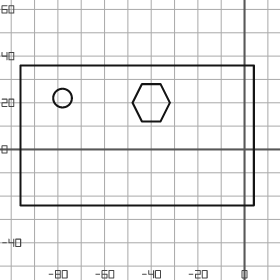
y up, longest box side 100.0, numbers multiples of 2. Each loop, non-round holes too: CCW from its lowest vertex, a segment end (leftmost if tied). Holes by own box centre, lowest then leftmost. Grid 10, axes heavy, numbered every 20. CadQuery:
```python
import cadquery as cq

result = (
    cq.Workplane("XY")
    .moveTo(-96.0, -24.0)
    .lineTo(4.0, -24.0)
    .lineTo(4.0, 36.0)
    .lineTo(-96.0, 36.0)
    .close()
    .moveTo(-44.0, 12.0)
    .lineTo(-36.0, 12.0)
    .lineTo(-32.0, 20.0)
    .lineTo(-36.0, 28.0)
    .lineTo(-44.0, 28.0)
    .lineTo(-48.0, 20.0)
    .close()
    .moveTo(-78.0, 22.0)
    .circle(4.0)
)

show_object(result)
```